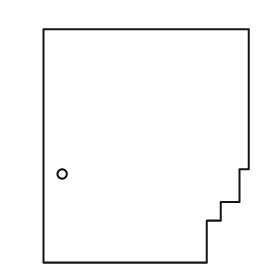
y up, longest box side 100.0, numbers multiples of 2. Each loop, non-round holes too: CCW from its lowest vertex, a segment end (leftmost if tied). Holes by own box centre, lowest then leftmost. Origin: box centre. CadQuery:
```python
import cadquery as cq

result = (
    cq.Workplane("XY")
    .moveTo(-44.0, -50.0)
    .lineTo(26.0, -50.0)
    .lineTo(26.0, -32.0)
    .lineTo(32.0, -32.0)
    .lineTo(32.0, -24.0)
    .lineTo(40.0, -24.0)
    .lineTo(40.0, -10.0)
    .lineTo(44.0, -10.0)
    .lineTo(44.0, 50.0)
    .lineTo(-44.0, 50.0)
    .close()
    .moveTo(-36.0, -12.0)
    .circle(2.0)
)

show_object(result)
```